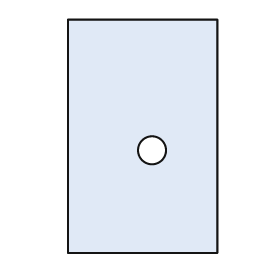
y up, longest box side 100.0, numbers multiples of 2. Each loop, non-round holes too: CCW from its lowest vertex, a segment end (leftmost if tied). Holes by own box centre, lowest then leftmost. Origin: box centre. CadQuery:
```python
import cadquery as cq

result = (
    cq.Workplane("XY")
    .moveTo(-32.0, -50.0)
    .lineTo(32.0, -50.0)
    .lineTo(32.0, 50.0)
    .lineTo(-32.0, 50.0)
    .close()
    .moveTo(4.0, -6.0)
    .circle(6.0)
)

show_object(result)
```